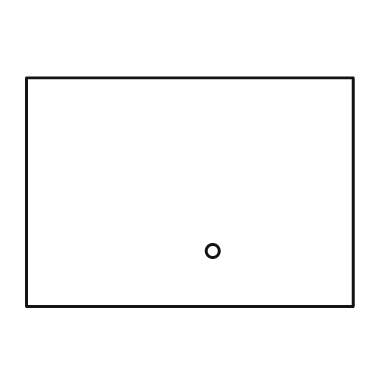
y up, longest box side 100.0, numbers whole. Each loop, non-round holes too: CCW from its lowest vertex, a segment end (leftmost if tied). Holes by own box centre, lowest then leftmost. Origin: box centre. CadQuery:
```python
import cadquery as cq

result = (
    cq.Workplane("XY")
    .moveTo(-50.0, -35.0)
    .lineTo(50.0, -35.0)
    .lineTo(50.0, 35.0)
    .lineTo(-50.0, 35.0)
    .close()
    .moveTo(7.0, -18.0)
    .circle(2.0)
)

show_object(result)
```